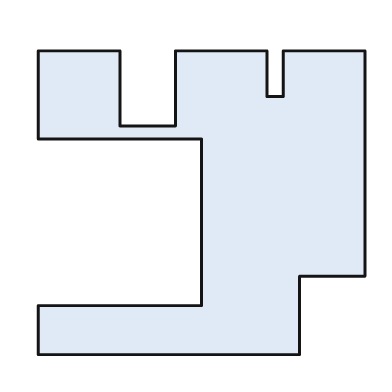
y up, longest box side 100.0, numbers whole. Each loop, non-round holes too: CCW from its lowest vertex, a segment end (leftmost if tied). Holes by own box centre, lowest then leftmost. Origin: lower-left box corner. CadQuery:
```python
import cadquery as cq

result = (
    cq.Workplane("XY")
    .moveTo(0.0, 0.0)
    .lineTo(80.0, 0.0)
    .lineTo(80.0, 24.0)
    .lineTo(100.0, 24.0)
    .lineTo(100.0, 93.0)
    .lineTo(75.0, 93.0)
    .lineTo(75.0, 79.0)
    .lineTo(70.0, 79.0)
    .lineTo(70.0, 93.0)
    .lineTo(42.0, 93.0)
    .lineTo(42.0, 70.0)
    .lineTo(25.0, 70.0)
    .lineTo(25.0, 93.0)
    .lineTo(0.0, 93.0)
    .lineTo(0.0, 66.0)
    .lineTo(50.0, 66.0)
    .lineTo(50.0, 15.0)
    .lineTo(0.0, 15.0)
    .close()
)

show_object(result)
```